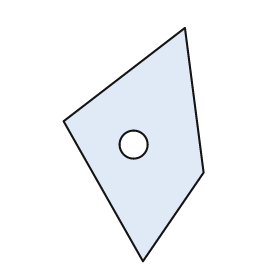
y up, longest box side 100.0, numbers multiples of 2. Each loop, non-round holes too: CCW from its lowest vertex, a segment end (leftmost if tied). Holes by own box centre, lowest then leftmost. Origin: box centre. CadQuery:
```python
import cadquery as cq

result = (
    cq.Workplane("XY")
    .moveTo(4.0, -50.0)
    .lineTo(30.0, -12.0)
    .lineTo(22.0, 50.0)
    .lineTo(-30.0, 10.0)
    .close()
    .moveTo(0.0, 0.0)
    .circle(6.0)
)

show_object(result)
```